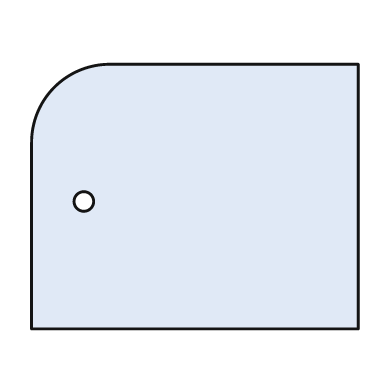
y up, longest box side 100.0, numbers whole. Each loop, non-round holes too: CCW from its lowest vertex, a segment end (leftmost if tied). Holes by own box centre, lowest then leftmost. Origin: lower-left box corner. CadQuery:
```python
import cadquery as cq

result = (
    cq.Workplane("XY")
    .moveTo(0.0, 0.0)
    .lineTo(100.0, 0.0)
    .lineTo(100.0, 81.0)
    .lineTo(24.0, 81.0)
    .threePointArc((7.0, 74.0), (0.0, 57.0))
    .close()
    .moveTo(16.0, 39.0)
    .circle(3.0)
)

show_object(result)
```